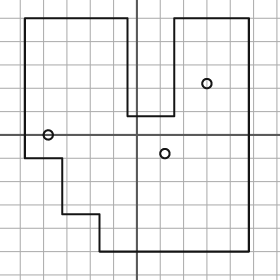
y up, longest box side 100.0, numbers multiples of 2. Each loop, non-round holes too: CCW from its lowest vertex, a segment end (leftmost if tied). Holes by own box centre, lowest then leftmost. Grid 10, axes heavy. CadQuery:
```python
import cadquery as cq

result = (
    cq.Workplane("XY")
    .moveTo(-16.0, -50.0)
    .lineTo(48.0, -50.0)
    .lineTo(48.0, 50.0)
    .lineTo(16.0, 50.0)
    .lineTo(16.0, 8.0)
    .lineTo(-4.0, 8.0)
    .lineTo(-4.0, 50.0)
    .lineTo(-48.0, 50.0)
    .lineTo(-48.0, -10.0)
    .lineTo(-32.0, -10.0)
    .lineTo(-32.0, -34.0)
    .lineTo(-16.0, -34.0)
    .close()
    .moveTo(12.0, -8.0)
    .circle(2.0)
    .moveTo(-38.0, 0.0)
    .circle(2.0)
    .moveTo(30.0, 22.0)
    .circle(2.0)
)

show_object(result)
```